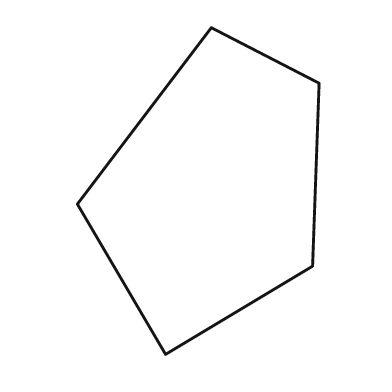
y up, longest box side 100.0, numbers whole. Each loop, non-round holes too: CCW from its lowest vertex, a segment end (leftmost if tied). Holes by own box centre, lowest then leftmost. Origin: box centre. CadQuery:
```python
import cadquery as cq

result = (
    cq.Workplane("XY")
    .moveTo(-10.0, -50.0)
    .lineTo(35.0, -23.0)
    .lineTo(37.0, 33.0)
    .lineTo(4.0, 50.0)
    .lineTo(-37.0, -4.0)
    .close()
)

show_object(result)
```